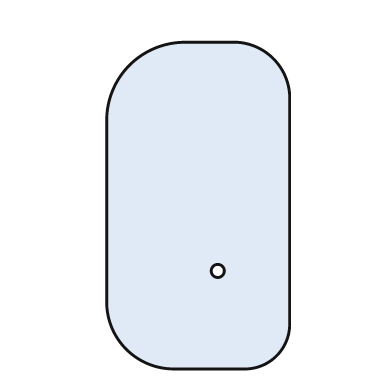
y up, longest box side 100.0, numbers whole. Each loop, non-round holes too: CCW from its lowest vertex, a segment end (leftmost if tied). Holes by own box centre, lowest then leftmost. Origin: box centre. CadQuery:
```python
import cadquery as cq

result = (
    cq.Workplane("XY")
    .moveTo(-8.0, -50.0)
    .lineTo(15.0, -50.0)
    .threePointArc((24.0, -46.0), (28.0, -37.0))
    .lineTo(28.0, 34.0)
    .threePointArc((23.0, 45.0), (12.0, 50.0))
    .lineTo(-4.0, 50.0)
    .threePointArc((-21.0, 43.0), (-28.0, 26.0))
    .lineTo(-28.0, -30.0)
    .threePointArc((-22.0, -44.0), (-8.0, -50.0))
    .close()
    .moveTo(6.0, -20.0)
    .circle(2.0)
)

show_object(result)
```